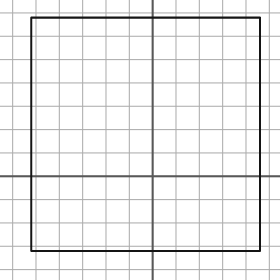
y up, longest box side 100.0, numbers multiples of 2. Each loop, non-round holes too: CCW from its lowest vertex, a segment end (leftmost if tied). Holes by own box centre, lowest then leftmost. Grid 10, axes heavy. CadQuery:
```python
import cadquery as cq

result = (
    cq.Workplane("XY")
    .moveTo(-52.0, -32.0)
    .lineTo(46.0, -32.0)
    .lineTo(46.0, 68.0)
    .lineTo(-52.0, 68.0)
    .close()
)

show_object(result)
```